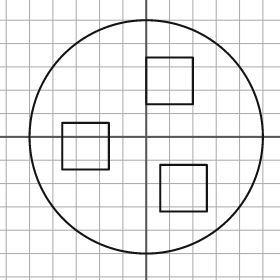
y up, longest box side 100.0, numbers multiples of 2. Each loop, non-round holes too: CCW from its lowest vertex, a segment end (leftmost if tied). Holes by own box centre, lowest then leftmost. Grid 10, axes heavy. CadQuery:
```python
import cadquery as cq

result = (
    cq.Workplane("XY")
    .moveTo(0.0, 0.0)
    .circle(50.0)
    .moveTo(6.0, -32.0)
    .lineTo(26.0, -32.0)
    .lineTo(26.0, -12.0)
    .lineTo(6.0, -12.0)
    .close()
    .moveTo(-36.0, -14.0)
    .lineTo(-16.0, -14.0)
    .lineTo(-16.0, 6.0)
    .lineTo(-36.0, 6.0)
    .close()
    .moveTo(0.0, 14.0)
    .lineTo(20.0, 14.0)
    .lineTo(20.0, 34.0)
    .lineTo(0.0, 34.0)
    .close()
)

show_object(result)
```